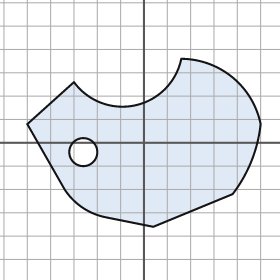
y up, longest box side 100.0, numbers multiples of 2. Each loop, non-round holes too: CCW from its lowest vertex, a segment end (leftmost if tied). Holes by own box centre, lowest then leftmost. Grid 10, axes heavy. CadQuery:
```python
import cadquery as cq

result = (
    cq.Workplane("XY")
    .moveTo(4.0, -36.0)
    .lineTo(38.0, -22.0)
    .threePointArc((46.0, -8.0), (50.0, 8.0))
    .threePointArc((38.0, 28.0), (16.0, 36.0))
    .threePointArc((-4.0, 16.0), (-30.0, 26.0))
    .lineTo(-50.0, 8.0)
    .lineTo(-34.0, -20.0)
    .threePointArc((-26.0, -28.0), (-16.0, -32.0))
    .close()
    .moveTo(-26.0, -4.0)
    .circle(6.0)
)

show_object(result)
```